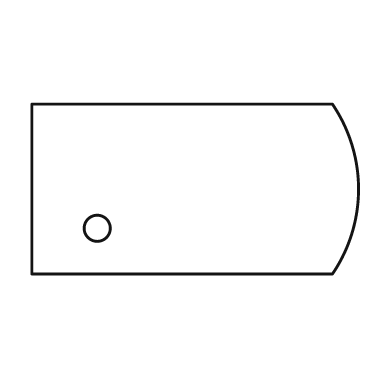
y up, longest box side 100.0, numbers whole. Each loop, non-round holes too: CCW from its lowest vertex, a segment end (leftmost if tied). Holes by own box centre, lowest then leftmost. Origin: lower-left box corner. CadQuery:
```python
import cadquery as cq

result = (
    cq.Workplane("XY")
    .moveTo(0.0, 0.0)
    .lineTo(92.0, 0.0)
    .threePointArc((100.0, 26.0), (92.0, 52.0))
    .lineTo(0.0, 52.0)
    .close()
    .moveTo(20.0, 14.0)
    .circle(4.0)
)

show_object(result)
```